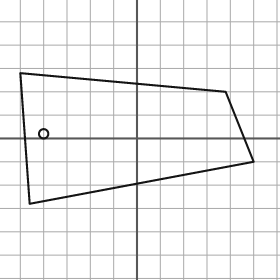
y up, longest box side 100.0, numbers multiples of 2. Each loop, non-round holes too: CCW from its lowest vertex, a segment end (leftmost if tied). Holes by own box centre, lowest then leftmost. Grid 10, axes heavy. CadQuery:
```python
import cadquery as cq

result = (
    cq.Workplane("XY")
    .moveTo(-46.0, -28.0)
    .lineTo(50.0, -10.0)
    .lineTo(38.0, 20.0)
    .lineTo(-50.0, 28.0)
    .close()
    .moveTo(-40.0, 2.0)
    .circle(2.0)
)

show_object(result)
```